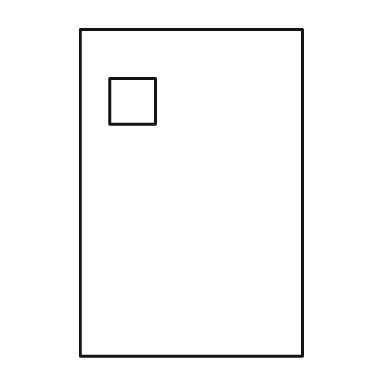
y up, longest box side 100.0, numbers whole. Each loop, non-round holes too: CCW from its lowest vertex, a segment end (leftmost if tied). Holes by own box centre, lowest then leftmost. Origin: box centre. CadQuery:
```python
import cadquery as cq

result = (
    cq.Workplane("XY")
    .moveTo(-34.0, -50.0)
    .lineTo(34.0, -50.0)
    .lineTo(34.0, 50.0)
    .lineTo(-34.0, 50.0)
    .close()
    .moveTo(-25.0, 21.0)
    .lineTo(-11.0, 21.0)
    .lineTo(-11.0, 35.0)
    .lineTo(-25.0, 35.0)
    .close()
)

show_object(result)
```